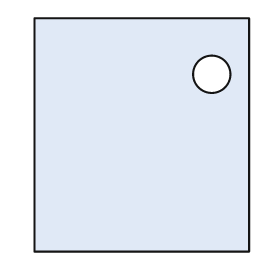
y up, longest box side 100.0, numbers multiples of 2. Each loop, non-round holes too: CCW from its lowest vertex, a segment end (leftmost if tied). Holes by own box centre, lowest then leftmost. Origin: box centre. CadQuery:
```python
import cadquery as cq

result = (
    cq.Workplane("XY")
    .moveTo(-46.0, -50.0)
    .lineTo(46.0, -50.0)
    .lineTo(46.0, 50.0)
    .lineTo(-46.0, 50.0)
    .close()
    .moveTo(30.0, 26.0)
    .circle(8.0)
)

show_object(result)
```